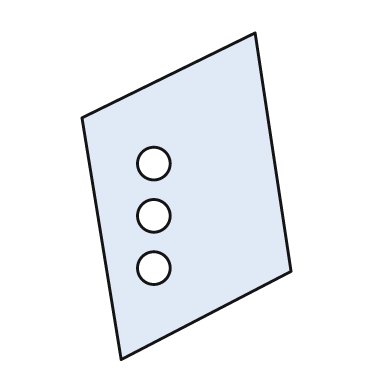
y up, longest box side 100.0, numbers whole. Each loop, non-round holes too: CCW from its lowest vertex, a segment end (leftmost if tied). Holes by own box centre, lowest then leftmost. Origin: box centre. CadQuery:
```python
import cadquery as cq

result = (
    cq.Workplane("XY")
    .moveTo(-20.0, -50.0)
    .lineTo(32.0, -23.0)
    .lineTo(21.0, 50.0)
    .lineTo(-32.0, 24.0)
    .close()
    .moveTo(-10.0, -22.0)
    .circle(5.0)
    .moveTo(-10.0, -6.0)
    .circle(5.0)
    .moveTo(-10.0, 10.0)
    .circle(5.0)
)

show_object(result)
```